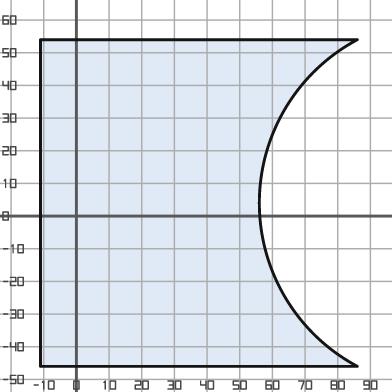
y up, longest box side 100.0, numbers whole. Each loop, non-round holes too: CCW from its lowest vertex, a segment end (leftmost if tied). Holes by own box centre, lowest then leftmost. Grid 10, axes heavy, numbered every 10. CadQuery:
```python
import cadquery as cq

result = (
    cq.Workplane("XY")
    .moveTo(-11.0, -46.0)
    .lineTo(86.0, -46.0)
    .threePointArc((56.0, 4.0), (86.0, 54.0))
    .lineTo(-11.0, 54.0)
    .close()
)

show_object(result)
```